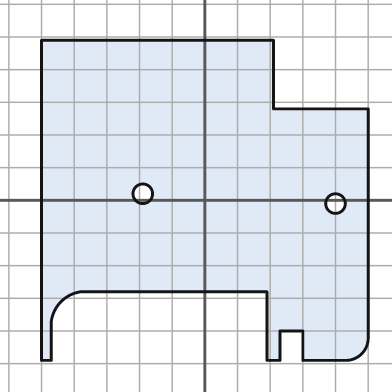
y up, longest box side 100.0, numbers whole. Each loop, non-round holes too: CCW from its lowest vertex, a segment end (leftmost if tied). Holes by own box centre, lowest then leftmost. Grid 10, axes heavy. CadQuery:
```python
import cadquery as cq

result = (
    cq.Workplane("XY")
    .moveTo(-50.0, -49.0)
    .lineTo(-47.0, -49.0)
    .lineTo(-47.0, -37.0)
    .threePointArc((-44.0, -31.0), (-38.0, -28.0))
    .lineTo(19.0, -28.0)
    .lineTo(19.0, -49.0)
    .lineTo(23.0, -49.0)
    .lineTo(23.0, -40.0)
    .lineTo(30.0, -40.0)
    .lineTo(30.0, -49.0)
    .lineTo(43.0, -49.0)
    .threePointArc((48.0, -47.0), (50.0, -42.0))
    .lineTo(50.0, 28.0)
    .lineTo(21.0, 28.0)
    .lineTo(21.0, 49.0)
    .lineTo(-50.0, 49.0)
    .close()
    .moveTo(40.0, -1.0)
    .circle(3.0)
    .moveTo(-19.0, 2.0)
    .circle(3.0)
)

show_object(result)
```